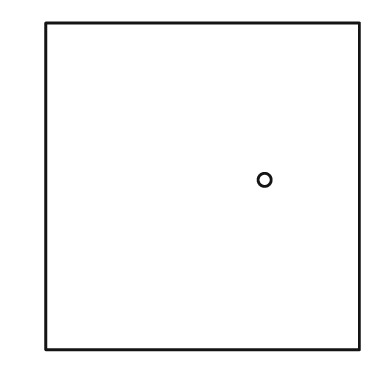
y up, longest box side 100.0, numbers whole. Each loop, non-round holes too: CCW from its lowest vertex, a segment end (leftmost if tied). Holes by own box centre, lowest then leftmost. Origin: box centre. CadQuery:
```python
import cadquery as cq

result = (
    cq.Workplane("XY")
    .moveTo(-48.0, -50.0)
    .lineTo(48.0, -50.0)
    .lineTo(48.0, 50.0)
    .lineTo(-48.0, 50.0)
    .close()
    .moveTo(19.0, 2.0)
    .circle(2.0)
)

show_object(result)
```